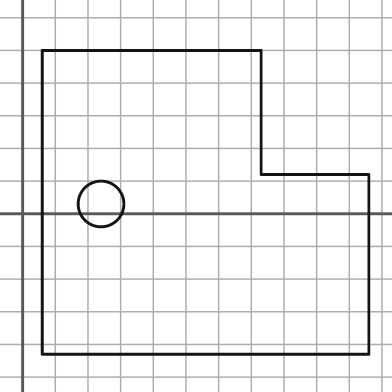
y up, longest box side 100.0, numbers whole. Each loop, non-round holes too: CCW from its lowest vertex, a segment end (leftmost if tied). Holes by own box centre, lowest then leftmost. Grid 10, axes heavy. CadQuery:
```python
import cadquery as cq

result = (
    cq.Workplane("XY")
    .moveTo(6.0, -43.0)
    .lineTo(106.0, -43.0)
    .lineTo(106.0, 12.0)
    .lineTo(73.0, 12.0)
    .lineTo(73.0, 50.0)
    .lineTo(6.0, 50.0)
    .close()
    .moveTo(24.0, 3.0)
    .circle(7.0)
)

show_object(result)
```